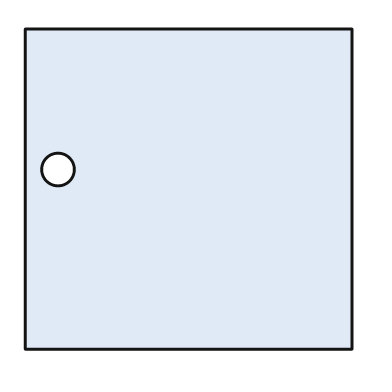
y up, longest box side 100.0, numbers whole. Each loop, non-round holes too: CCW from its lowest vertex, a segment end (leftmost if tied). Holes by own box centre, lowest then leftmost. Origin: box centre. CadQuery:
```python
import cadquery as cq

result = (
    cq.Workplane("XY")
    .moveTo(-50.0, -49.0)
    .lineTo(50.0, -49.0)
    .lineTo(50.0, 49.0)
    .lineTo(-50.0, 49.0)
    .close()
    .moveTo(-40.0, 6.0)
    .circle(5.0)
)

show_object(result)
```